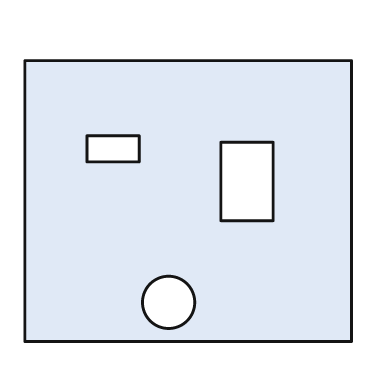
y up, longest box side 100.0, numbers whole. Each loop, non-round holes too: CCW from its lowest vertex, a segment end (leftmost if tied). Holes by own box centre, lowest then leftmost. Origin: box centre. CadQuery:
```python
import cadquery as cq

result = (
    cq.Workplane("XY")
    .moveTo(-50.0, -43.0)
    .lineTo(50.0, -43.0)
    .lineTo(50.0, 43.0)
    .lineTo(-50.0, 43.0)
    .close()
    .moveTo(-6.0, -31.0)
    .circle(8.0)
    .moveTo(10.0, -6.0)
    .lineTo(26.0, -6.0)
    .lineTo(26.0, 18.0)
    .lineTo(10.0, 18.0)
    .close()
    .moveTo(-31.0, 12.0)
    .lineTo(-15.0, 12.0)
    .lineTo(-15.0, 20.0)
    .lineTo(-31.0, 20.0)
    .close()
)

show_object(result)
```